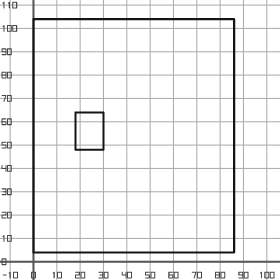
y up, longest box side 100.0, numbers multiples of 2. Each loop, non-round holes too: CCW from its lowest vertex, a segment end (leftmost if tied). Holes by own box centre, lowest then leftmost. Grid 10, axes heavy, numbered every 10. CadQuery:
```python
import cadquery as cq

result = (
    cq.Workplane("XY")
    .moveTo(0.0, 4.0)
    .lineTo(86.0, 4.0)
    .lineTo(86.0, 104.0)
    .lineTo(0.0, 104.0)
    .close()
    .moveTo(18.0, 48.0)
    .lineTo(30.0, 48.0)
    .lineTo(30.0, 64.0)
    .lineTo(18.0, 64.0)
    .close()
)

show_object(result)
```